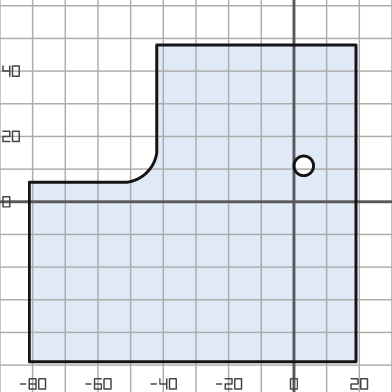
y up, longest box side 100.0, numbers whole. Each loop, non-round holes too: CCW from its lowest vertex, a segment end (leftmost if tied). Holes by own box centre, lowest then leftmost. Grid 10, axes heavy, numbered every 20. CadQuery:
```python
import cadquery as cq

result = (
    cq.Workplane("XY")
    .moveTo(-81.0, -49.0)
    .lineTo(19.0, -49.0)
    .lineTo(19.0, 48.0)
    .lineTo(-42.0, 48.0)
    .lineTo(-42.0, 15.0)
    .threePointArc((-45.0, 9.0), (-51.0, 6.0))
    .lineTo(-81.0, 6.0)
    .close()
    .moveTo(3.0, 11.0)
    .circle(3.0)
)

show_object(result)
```